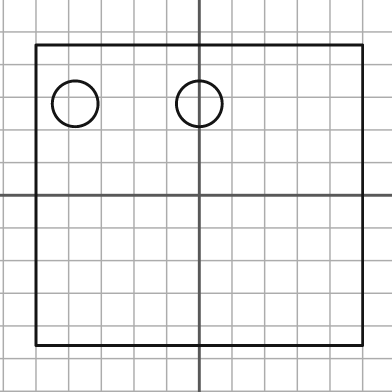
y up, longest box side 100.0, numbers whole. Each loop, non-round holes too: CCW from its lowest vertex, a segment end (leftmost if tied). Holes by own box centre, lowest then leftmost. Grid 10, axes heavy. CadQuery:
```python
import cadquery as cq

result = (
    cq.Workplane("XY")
    .moveTo(-50.0, -46.0)
    .lineTo(50.0, -46.0)
    .lineTo(50.0, 46.0)
    .lineTo(-50.0, 46.0)
    .close()
    .moveTo(-38.0, 28.0)
    .circle(7.0)
    .moveTo(0.0, 28.0)
    .circle(7.0)
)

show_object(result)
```